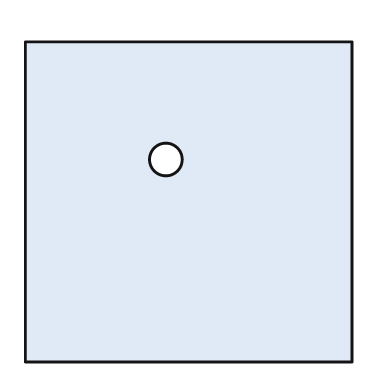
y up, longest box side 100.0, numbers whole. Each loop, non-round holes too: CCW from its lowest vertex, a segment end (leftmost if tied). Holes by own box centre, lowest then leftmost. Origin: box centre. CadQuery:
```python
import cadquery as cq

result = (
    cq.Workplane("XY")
    .moveTo(-50.0, -49.0)
    .lineTo(50.0, -49.0)
    .lineTo(50.0, 49.0)
    .lineTo(-50.0, 49.0)
    .close()
    .moveTo(-7.0, 13.0)
    .circle(5.0)
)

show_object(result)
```